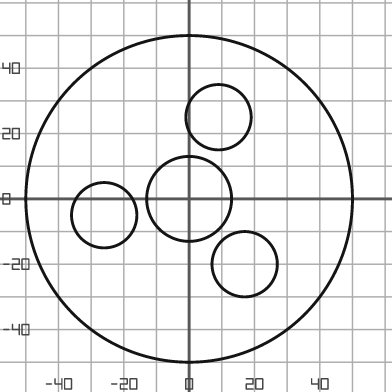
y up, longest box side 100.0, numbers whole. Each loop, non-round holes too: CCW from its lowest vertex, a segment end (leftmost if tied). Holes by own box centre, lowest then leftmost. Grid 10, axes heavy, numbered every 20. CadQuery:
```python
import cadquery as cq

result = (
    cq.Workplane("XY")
    .moveTo(0.0, 0.0)
    .circle(50.0)
    .moveTo(17.0, -20.0)
    .circle(10.0)
    .moveTo(-26.0, -5.0)
    .circle(10.0)
    .moveTo(0.0, 0.0)
    .circle(13.0)
    .moveTo(9.0, 25.0)
    .circle(10.0)
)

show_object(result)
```